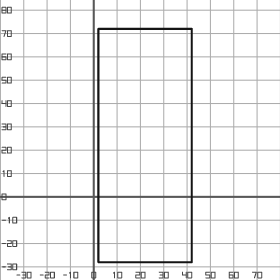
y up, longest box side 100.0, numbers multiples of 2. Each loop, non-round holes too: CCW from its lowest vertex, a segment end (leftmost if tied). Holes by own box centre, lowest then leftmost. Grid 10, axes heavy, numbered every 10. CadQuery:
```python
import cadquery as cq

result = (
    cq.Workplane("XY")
    .moveTo(2.0, -28.0)
    .lineTo(42.0, -28.0)
    .lineTo(42.0, 72.0)
    .lineTo(2.0, 72.0)
    .close()
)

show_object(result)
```